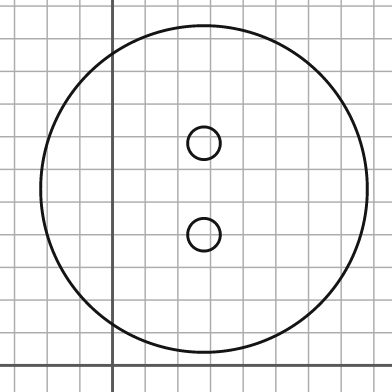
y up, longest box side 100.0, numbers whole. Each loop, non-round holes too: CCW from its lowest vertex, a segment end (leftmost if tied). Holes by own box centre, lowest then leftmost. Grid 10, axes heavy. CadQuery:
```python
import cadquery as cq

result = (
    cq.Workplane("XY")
    .moveTo(28.0, 54.0)
    .circle(50.0)
    .moveTo(28.0, 40.0)
    .circle(5.0)
    .moveTo(28.0, 68.0)
    .circle(5.0)
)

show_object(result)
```